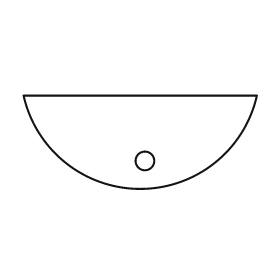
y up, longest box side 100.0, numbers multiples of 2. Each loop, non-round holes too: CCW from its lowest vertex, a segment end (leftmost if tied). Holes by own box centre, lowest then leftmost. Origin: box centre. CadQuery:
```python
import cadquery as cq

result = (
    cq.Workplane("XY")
    .moveTo(-50.0, 20.0)
    .threePointArc((0.0, -20.0), (50.0, 20.0))
    .close()
    .moveTo(2.0, -8.0)
    .circle(4.0)
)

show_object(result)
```